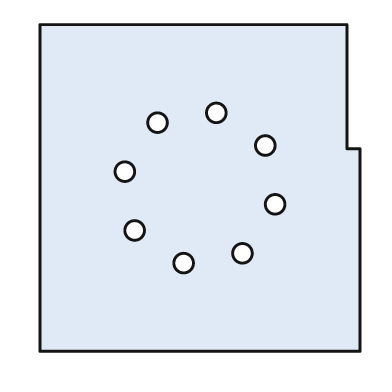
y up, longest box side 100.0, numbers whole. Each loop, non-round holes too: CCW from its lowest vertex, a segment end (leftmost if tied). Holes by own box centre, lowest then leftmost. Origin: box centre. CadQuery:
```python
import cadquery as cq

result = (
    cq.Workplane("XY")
    .moveTo(-49.0, -50.0)
    .lineTo(49.0, -50.0)
    .lineTo(49.0, 12.0)
    .lineTo(45.0, 12.0)
    .lineTo(45.0, 50.0)
    .lineTo(-49.0, 50.0)
    .close()
    .moveTo(-5.0, -23.0)
    .circle(3.0)
    .moveTo(13.0, -20.0)
    .circle(3.0)
    .moveTo(-20.0, -13.0)
    .circle(3.0)
    .moveTo(23.0, -5.0)
    .circle(3.0)
    .moveTo(-23.0, 5.0)
    .circle(3.0)
    .moveTo(20.0, 13.0)
    .circle(3.0)
    .moveTo(-13.0, 20.0)
    .circle(3.0)
    .moveTo(5.0, 23.0)
    .circle(3.0)
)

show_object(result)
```